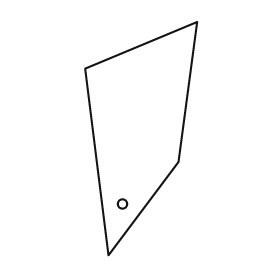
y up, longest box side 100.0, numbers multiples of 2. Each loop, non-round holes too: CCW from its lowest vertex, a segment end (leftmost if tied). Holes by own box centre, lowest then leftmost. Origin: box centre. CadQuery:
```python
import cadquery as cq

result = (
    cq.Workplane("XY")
    .moveTo(-14.0, -50.0)
    .lineTo(16.0, -10.0)
    .lineTo(24.0, 50.0)
    .lineTo(-24.0, 30.0)
    .close()
    .moveTo(-8.0, -28.0)
    .circle(2.0)
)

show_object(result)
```